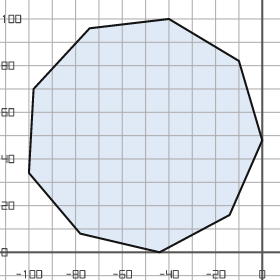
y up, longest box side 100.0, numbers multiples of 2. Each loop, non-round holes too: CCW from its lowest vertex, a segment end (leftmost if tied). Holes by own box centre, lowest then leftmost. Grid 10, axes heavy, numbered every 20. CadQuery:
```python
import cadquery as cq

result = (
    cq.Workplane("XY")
    .moveTo(-44.0, 0.0)
    .lineTo(-14.0, 16.0)
    .lineTo(0.0, 48.0)
    .lineTo(-10.0, 82.0)
    .lineTo(-40.0, 100.0)
    .lineTo(-74.0, 96.0)
    .lineTo(-98.0, 70.0)
    .lineTo(-100.0, 34.0)
    .lineTo(-78.0, 8.0)
    .close()
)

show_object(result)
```